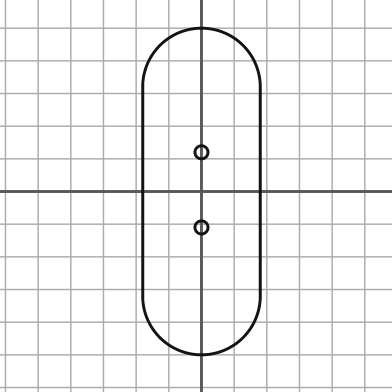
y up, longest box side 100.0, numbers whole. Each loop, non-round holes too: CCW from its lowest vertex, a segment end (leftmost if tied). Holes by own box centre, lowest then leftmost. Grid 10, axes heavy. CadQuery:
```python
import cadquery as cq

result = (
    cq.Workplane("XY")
    .moveTo(-18.0, -32.0)
    .threePointArc((0.0, -50.0), (18.0, -32.0))
    .lineTo(18.0, 32.0)
    .threePointArc((0.0, 50.0), (-18.0, 32.0))
    .close()
    .moveTo(0.0, -11.0)
    .circle(2.0)
    .moveTo(0.0, 12.0)
    .circle(2.0)
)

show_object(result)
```